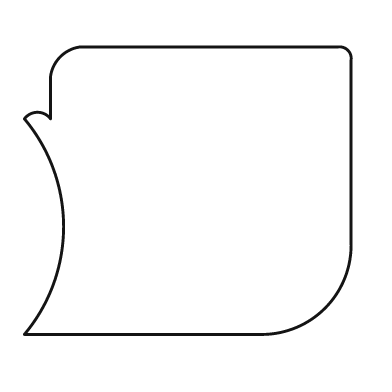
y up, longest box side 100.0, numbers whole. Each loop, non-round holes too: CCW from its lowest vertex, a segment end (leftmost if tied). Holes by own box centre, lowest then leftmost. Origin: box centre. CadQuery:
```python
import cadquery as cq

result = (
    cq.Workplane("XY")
    .moveTo(-50.0, -44.0)
    .lineTo(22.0, -44.0)
    .threePointArc((42.0, -36.0), (50.0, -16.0))
    .lineTo(50.0, 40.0)
    .threePointArc((49.0, 43.0), (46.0, 44.0))
    .lineTo(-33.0, 44.0)
    .threePointArc((-39.0, 41.0), (-42.0, 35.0))
    .lineTo(-42.0, 22.0)
    .threePointArc((-46.0, 24.0), (-50.0, 22.0))
    .threePointArc((-38.0, -11.0), (-50.0, -44.0))
    .close()
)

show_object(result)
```